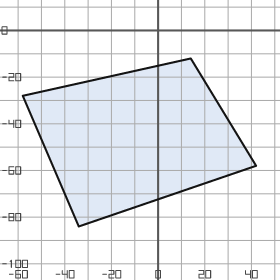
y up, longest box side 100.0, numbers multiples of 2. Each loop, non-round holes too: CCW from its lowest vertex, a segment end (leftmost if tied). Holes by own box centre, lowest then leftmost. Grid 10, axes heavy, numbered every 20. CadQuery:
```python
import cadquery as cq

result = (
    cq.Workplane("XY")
    .moveTo(-34.0, -84.0)
    .lineTo(42.0, -58.0)
    .lineTo(14.0, -12.0)
    .lineTo(-58.0, -28.0)
    .close()
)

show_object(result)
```